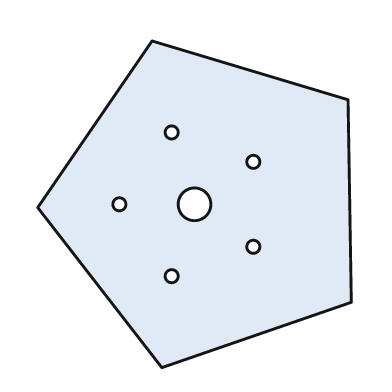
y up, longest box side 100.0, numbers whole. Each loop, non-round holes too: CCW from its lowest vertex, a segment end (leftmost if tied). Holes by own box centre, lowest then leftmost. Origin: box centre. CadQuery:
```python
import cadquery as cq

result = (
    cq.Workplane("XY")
    .moveTo(-10.0, -50.0)
    .lineTo(48.0, -30.0)
    .lineTo(47.0, 32.0)
    .lineTo(-13.0, 50.0)
    .lineTo(-48.0, -1.0)
    .close()
    .moveTo(-7.0, -22.0)
    .circle(2.0)
    .moveTo(18.0, -13.0)
    .circle(2.0)
    .moveTo(-23.0, 0.0)
    .circle(2.0)
    .moveTo(0.0, 0.0)
    .circle(5.0)
    .moveTo(18.0, 13.0)
    .circle(2.0)
    .moveTo(-7.0, 22.0)
    .circle(2.0)
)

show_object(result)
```